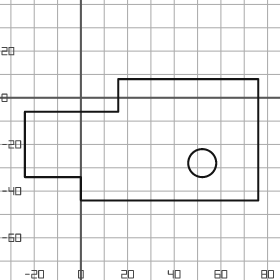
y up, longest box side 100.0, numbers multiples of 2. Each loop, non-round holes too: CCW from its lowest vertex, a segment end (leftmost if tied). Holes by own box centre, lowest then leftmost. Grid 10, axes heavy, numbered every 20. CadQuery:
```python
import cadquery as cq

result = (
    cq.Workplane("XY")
    .moveTo(0.0, -44.0)
    .lineTo(76.0, -44.0)
    .lineTo(76.0, 8.0)
    .lineTo(16.0, 8.0)
    .lineTo(16.0, -6.0)
    .lineTo(-24.0, -6.0)
    .lineTo(-24.0, -34.0)
    .lineTo(0.0, -34.0)
    .close()
    .moveTo(52.0, -28.0)
    .circle(6.0)
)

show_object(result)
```